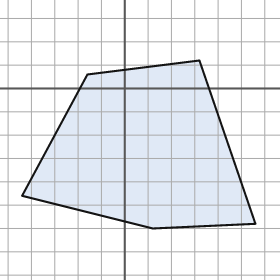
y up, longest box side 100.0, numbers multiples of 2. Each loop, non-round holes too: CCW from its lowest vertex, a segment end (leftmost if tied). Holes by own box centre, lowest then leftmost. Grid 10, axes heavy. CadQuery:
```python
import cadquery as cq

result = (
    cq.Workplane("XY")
    .moveTo(12.0, -60.0)
    .lineTo(56.0, -58.0)
    .lineTo(32.0, 12.0)
    .lineTo(-16.0, 6.0)
    .lineTo(-44.0, -46.0)
    .close()
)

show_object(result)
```